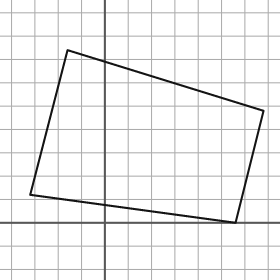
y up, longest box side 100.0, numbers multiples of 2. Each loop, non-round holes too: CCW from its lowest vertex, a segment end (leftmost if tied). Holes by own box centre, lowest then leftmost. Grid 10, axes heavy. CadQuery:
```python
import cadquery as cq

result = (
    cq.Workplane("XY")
    .moveTo(56.0, 0.0)
    .lineTo(68.0, 48.0)
    .lineTo(-16.0, 74.0)
    .lineTo(-32.0, 12.0)
    .close()
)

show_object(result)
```